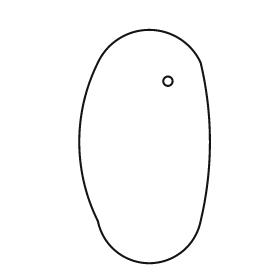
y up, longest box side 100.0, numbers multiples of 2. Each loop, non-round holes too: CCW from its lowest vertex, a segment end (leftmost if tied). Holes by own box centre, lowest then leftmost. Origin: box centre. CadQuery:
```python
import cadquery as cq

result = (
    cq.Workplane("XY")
    .moveTo(-20.0, -32.0)
    .threePointArc((2.0, -50.0), (24.0, -32.0))
    .threePointArc((28.0, 2.0), (24.0, 36.0))
    .threePointArc((2.0, 50.0), (-20.0, 36.0))
    .threePointArc((-28.0, 2.0), (-20.0, -32.0))
    .close()
    .moveTo(10.0, 28.0)
    .circle(2.0)
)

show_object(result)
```